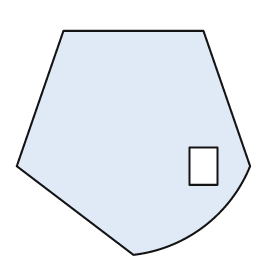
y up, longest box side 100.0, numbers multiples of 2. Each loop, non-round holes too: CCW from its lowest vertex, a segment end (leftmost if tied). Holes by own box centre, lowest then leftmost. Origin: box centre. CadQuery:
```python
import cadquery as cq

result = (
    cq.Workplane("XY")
    .moveTo(0.0, -48.0)
    .threePointArc((30.0, -36.0), (50.0, -10.0))
    .lineTo(30.0, 48.0)
    .lineTo(-30.0, 48.0)
    .lineTo(-50.0, -10.0)
    .close()
    .moveTo(24.0, -18.0)
    .lineTo(36.0, -18.0)
    .lineTo(36.0, -2.0)
    .lineTo(24.0, -2.0)
    .close()
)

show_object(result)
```